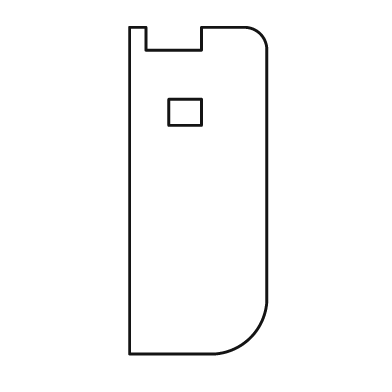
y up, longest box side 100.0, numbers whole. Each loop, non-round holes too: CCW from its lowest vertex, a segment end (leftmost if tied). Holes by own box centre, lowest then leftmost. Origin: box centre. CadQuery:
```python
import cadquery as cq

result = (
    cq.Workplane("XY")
    .moveTo(-21.0, -50.0)
    .lineTo(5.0, -50.0)
    .threePointArc((16.0, -45.0), (21.0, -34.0))
    .lineTo(21.0, 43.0)
    .threePointArc((19.0, 48.0), (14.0, 50.0))
    .lineTo(1.0, 50.0)
    .lineTo(1.0, 43.0)
    .lineTo(-16.0, 43.0)
    .lineTo(-16.0, 50.0)
    .lineTo(-21.0, 50.0)
    .close()
    .moveTo(-9.0, 20.0)
    .lineTo(1.0, 20.0)
    .lineTo(1.0, 28.0)
    .lineTo(-9.0, 28.0)
    .close()
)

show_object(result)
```